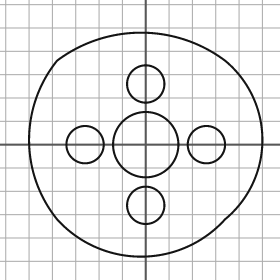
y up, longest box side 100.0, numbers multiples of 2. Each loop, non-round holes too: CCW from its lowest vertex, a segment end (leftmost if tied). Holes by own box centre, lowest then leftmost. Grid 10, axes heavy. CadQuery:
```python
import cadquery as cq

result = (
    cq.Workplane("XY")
    .moveTo(-38.0, -32.0)
    .threePointArc((-2.0, -48.0), (34.0, -32.0))
    .threePointArc((50.0, 2.0), (34.0, 36.0))
    .threePointArc((-2.0, 48.0), (-38.0, 36.0))
    .threePointArc((-50.0, 2.0), (-38.0, -32.0))
    .close()
    .moveTo(0.0, -26.0)
    .circle(8.0)
    .moveTo(-26.0, 0.0)
    .circle(8.0)
    .moveTo(0.0, 0.0)
    .circle(14.0)
    .moveTo(26.0, 0.0)
    .circle(8.0)
    .moveTo(0.0, 26.0)
    .circle(8.0)
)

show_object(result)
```